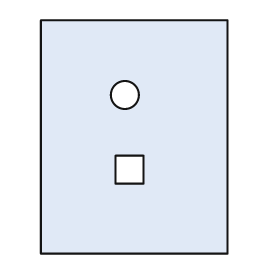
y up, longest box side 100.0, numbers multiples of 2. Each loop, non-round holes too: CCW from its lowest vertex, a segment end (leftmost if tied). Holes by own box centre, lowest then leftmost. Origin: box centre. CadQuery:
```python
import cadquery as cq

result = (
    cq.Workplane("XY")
    .moveTo(-40.0, -50.0)
    .lineTo(40.0, -50.0)
    .lineTo(40.0, 50.0)
    .lineTo(-40.0, 50.0)
    .close()
    .moveTo(-8.0, -20.0)
    .lineTo(4.0, -20.0)
    .lineTo(4.0, -8.0)
    .lineTo(-8.0, -8.0)
    .close()
    .moveTo(-4.0, 18.0)
    .circle(6.0)
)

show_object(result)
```